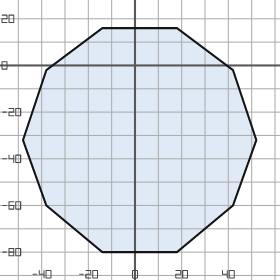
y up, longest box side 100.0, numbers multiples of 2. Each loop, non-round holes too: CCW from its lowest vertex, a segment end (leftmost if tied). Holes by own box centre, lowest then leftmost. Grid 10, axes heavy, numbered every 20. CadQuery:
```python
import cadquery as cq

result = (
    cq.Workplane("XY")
    .moveTo(-14.0, -80.0)
    .lineTo(18.0, -80.0)
    .lineTo(42.0, -60.0)
    .lineTo(52.0, -32.0)
    .lineTo(42.0, -2.0)
    .lineTo(18.0, 16.0)
    .lineTo(-14.0, 16.0)
    .lineTo(-38.0, -2.0)
    .lineTo(-48.0, -32.0)
    .lineTo(-38.0, -60.0)
    .close()
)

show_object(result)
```